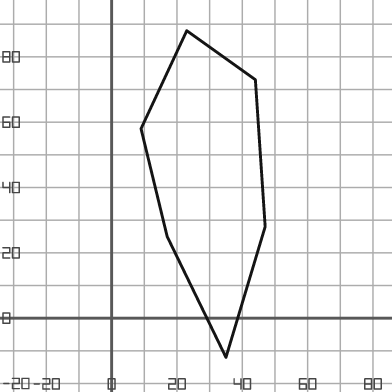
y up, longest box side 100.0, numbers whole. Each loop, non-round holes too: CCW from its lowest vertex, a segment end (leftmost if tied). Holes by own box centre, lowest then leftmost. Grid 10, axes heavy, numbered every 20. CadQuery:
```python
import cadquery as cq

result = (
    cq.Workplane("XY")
    .moveTo(35.0, -12.0)
    .lineTo(47.0, 28.0)
    .lineTo(44.0, 73.0)
    .lineTo(23.0, 88.0)
    .lineTo(9.0, 58.0)
    .lineTo(17.0, 25.0)
    .close()
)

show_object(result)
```